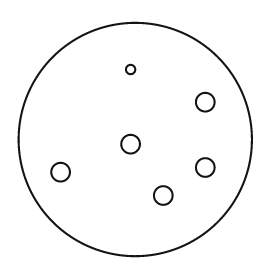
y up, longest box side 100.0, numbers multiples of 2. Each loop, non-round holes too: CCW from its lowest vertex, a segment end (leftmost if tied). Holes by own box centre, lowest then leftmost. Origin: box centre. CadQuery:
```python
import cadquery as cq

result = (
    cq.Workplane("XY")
    .moveTo(0.0, 0.0)
    .circle(50.0)
    .moveTo(12.0, -24.0)
    .circle(4.0)
    .moveTo(-32.0, -14.0)
    .circle(4.0)
    .moveTo(30.0, -12.0)
    .circle(4.0)
    .moveTo(-2.0, -2.0)
    .circle(4.0)
    .moveTo(30.0, 16.0)
    .circle(4.0)
    .moveTo(-2.0, 30.0)
    .circle(2.0)
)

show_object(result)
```